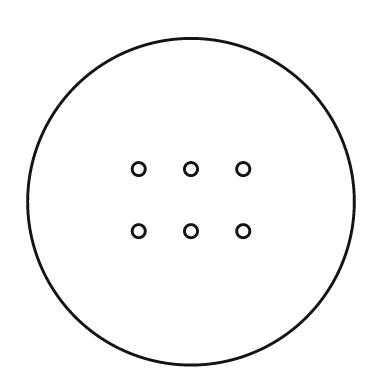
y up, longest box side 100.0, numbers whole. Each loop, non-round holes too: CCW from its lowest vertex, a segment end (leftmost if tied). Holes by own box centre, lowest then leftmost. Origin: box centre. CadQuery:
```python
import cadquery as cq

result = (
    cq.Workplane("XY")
    .moveTo(0.0, 0.0)
    .circle(50.0)
    .moveTo(-16.0, -9.0)
    .circle(2.0)
    .moveTo(0.0, -9.0)
    .circle(2.0)
    .moveTo(16.0, -9.0)
    .circle(2.0)
    .moveTo(-16.0, 10.0)
    .circle(2.0)
    .moveTo(0.0, 10.0)
    .circle(2.0)
    .moveTo(16.0, 10.0)
    .circle(2.0)
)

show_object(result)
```